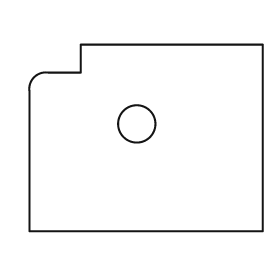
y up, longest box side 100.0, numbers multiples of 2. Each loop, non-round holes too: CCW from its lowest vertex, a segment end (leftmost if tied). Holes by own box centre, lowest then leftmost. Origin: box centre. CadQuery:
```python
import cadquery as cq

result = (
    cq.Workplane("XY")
    .moveTo(-50.0, -40.0)
    .lineTo(50.0, -40.0)
    .lineTo(50.0, 40.0)
    .lineTo(-28.0, 40.0)
    .lineTo(-28.0, 28.0)
    .lineTo(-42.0, 28.0)
    .threePointArc((-48.0, 26.0), (-50.0, 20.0))
    .close()
    .moveTo(-4.0, 6.0)
    .circle(8.0)
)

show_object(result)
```